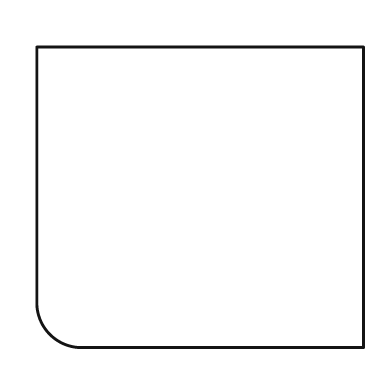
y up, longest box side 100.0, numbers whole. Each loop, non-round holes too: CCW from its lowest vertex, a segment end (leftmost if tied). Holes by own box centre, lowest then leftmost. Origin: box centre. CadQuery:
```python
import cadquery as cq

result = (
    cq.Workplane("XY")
    .moveTo(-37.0, -46.0)
    .lineTo(50.0, -46.0)
    .lineTo(50.0, 46.0)
    .lineTo(-50.0, 46.0)
    .lineTo(-50.0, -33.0)
    .threePointArc((-46.0, -42.0), (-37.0, -46.0))
    .close()
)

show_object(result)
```